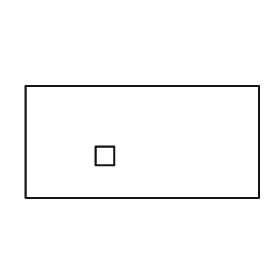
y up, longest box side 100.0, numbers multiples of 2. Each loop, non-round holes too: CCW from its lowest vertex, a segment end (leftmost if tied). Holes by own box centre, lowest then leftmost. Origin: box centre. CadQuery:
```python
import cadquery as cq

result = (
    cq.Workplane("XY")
    .moveTo(-50.0, -24.0)
    .lineTo(50.0, -24.0)
    .lineTo(50.0, 24.0)
    .lineTo(-50.0, 24.0)
    .close()
    .moveTo(-20.0, -10.0)
    .lineTo(-12.0, -10.0)
    .lineTo(-12.0, -2.0)
    .lineTo(-20.0, -2.0)
    .close()
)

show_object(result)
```